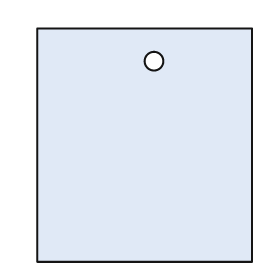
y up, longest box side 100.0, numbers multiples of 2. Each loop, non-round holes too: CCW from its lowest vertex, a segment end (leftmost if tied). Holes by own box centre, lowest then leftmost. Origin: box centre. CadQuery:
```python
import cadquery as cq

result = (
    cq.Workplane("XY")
    .moveTo(-46.0, -50.0)
    .lineTo(46.0, -50.0)
    .lineTo(46.0, 50.0)
    .lineTo(-46.0, 50.0)
    .close()
    .moveTo(4.0, 36.0)
    .circle(4.0)
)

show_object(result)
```